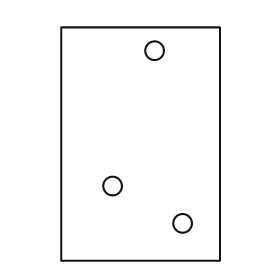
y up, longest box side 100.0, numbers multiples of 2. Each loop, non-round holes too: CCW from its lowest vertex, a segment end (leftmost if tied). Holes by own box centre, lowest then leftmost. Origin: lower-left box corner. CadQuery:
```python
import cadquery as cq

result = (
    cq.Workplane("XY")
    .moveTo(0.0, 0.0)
    .lineTo(68.0, 0.0)
    .lineTo(68.0, 100.0)
    .lineTo(0.0, 100.0)
    .close()
    .moveTo(52.0, 16.0)
    .circle(4.0)
    .moveTo(22.0, 32.0)
    .circle(4.0)
    .moveTo(40.0, 90.0)
    .circle(4.0)
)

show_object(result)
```